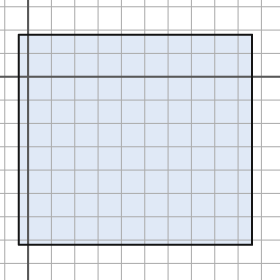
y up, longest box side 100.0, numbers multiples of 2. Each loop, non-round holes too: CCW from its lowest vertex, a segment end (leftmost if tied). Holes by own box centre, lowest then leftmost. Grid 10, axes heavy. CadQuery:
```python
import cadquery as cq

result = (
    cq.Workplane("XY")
    .moveTo(-4.0, -72.0)
    .lineTo(96.0, -72.0)
    .lineTo(96.0, 18.0)
    .lineTo(-4.0, 18.0)
    .close()
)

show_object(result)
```